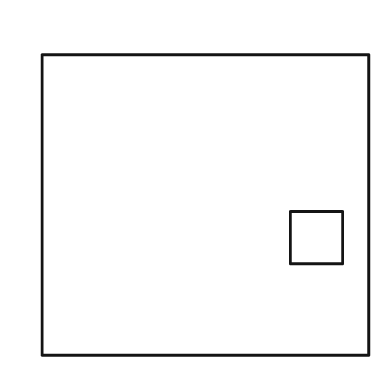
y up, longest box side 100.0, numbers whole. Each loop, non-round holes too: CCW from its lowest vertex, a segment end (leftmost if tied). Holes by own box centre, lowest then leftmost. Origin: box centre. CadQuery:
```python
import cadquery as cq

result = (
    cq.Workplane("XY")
    .moveTo(-50.0, -46.0)
    .lineTo(50.0, -46.0)
    .lineTo(50.0, 46.0)
    .lineTo(-50.0, 46.0)
    .close()
    .moveTo(26.0, -18.0)
    .lineTo(42.0, -18.0)
    .lineTo(42.0, -2.0)
    .lineTo(26.0, -2.0)
    .close()
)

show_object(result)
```